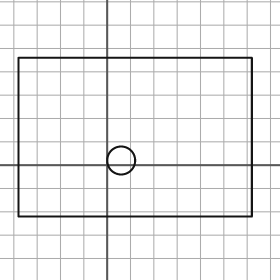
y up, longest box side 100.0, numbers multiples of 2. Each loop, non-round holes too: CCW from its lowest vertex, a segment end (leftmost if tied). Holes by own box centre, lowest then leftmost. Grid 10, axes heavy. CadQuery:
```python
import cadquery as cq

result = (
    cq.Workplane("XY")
    .moveTo(-38.0, -22.0)
    .lineTo(62.0, -22.0)
    .lineTo(62.0, 46.0)
    .lineTo(-38.0, 46.0)
    .close()
    .moveTo(6.0, 2.0)
    .circle(6.0)
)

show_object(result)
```